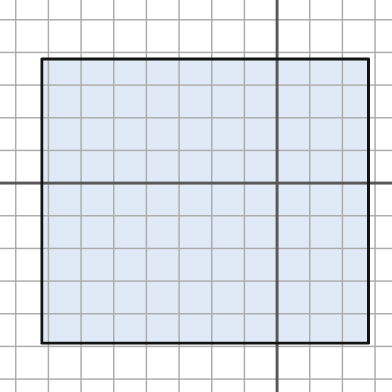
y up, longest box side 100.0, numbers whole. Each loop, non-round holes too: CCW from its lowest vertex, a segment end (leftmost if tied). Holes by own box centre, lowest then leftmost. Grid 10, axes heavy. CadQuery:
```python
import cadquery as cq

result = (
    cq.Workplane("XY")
    .moveTo(-72.0, -49.0)
    .lineTo(28.0, -49.0)
    .lineTo(28.0, 38.0)
    .lineTo(-72.0, 38.0)
    .close()
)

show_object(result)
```